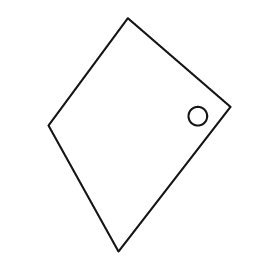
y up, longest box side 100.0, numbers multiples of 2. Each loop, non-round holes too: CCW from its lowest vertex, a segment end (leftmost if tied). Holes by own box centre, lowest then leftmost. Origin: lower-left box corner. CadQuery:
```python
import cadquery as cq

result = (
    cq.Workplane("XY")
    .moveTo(30.0, 0.0)
    .lineTo(78.0, 62.0)
    .lineTo(34.0, 100.0)
    .lineTo(0.0, 54.0)
    .close()
    .moveTo(64.0, 58.0)
    .circle(4.0)
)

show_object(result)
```